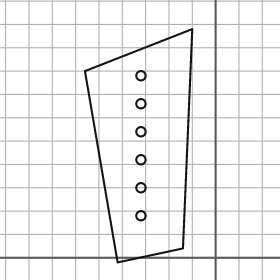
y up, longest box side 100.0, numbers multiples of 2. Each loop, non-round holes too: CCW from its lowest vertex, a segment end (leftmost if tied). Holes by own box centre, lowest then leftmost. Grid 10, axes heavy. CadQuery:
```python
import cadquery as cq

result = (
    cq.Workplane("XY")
    .moveTo(-42.0, -2.0)
    .lineTo(-14.0, 4.0)
    .lineTo(-10.0, 98.0)
    .lineTo(-56.0, 80.0)
    .close()
    .moveTo(-32.0, 18.0)
    .circle(2.0)
    .moveTo(-32.0, 30.0)
    .circle(2.0)
    .moveTo(-32.0, 42.0)
    .circle(2.0)
    .moveTo(-32.0, 54.0)
    .circle(2.0)
    .moveTo(-32.0, 66.0)
    .circle(2.0)
    .moveTo(-32.0, 78.0)
    .circle(2.0)
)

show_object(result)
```